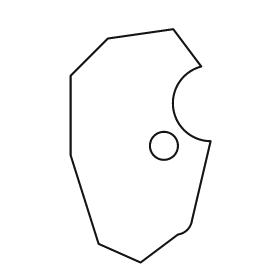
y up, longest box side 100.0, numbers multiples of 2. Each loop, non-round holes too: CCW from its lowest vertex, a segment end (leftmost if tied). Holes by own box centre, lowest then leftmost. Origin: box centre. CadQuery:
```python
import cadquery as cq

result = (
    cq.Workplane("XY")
    .moveTo(0.0, -50.0)
    .lineTo(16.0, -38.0)
    .threePointArc((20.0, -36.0), (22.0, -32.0))
    .lineTo(30.0, 2.0)
    .threePointArc((14.0, 16.0), (26.0, 34.0))
    .lineTo(14.0, 50.0)
    .lineTo(-14.0, 46.0)
    .lineTo(-30.0, 30.0)
    .lineTo(-30.0, -4.0)
    .lineTo(-18.0, -42.0)
    .close()
    .moveTo(10.0, 0.0)
    .circle(6.0)
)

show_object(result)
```